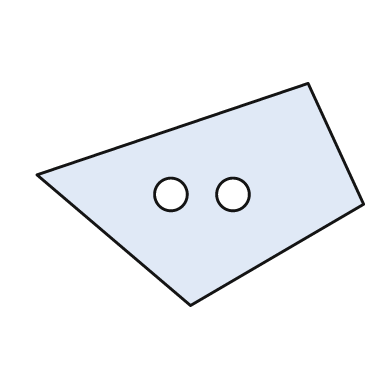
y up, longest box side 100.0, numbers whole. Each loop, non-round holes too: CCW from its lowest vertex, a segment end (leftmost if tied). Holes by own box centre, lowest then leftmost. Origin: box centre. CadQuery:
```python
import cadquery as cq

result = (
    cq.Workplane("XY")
    .moveTo(-3.0, -34.0)
    .lineTo(50.0, -3.0)
    .lineTo(33.0, 34.0)
    .lineTo(-50.0, 6.0)
    .close()
    .moveTo(-9.0, 0.0)
    .circle(5.0)
    .moveTo(10.0, 0.0)
    .circle(5.0)
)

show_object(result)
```